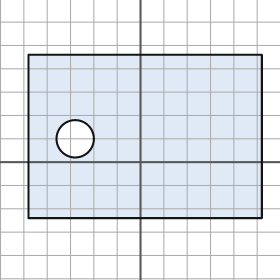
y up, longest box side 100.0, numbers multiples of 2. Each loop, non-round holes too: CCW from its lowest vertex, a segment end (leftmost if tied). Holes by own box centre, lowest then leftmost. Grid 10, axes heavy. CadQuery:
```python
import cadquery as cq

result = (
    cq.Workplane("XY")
    .moveTo(-48.0, -24.0)
    .lineTo(52.0, -24.0)
    .lineTo(52.0, 46.0)
    .lineTo(-48.0, 46.0)
    .close()
    .moveTo(-28.0, 10.0)
    .circle(8.0)
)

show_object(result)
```